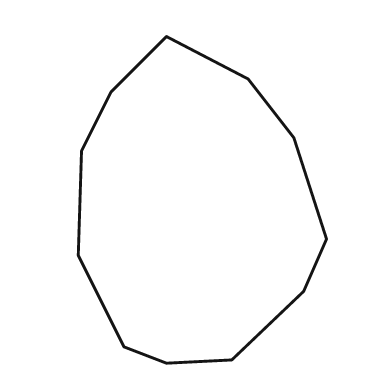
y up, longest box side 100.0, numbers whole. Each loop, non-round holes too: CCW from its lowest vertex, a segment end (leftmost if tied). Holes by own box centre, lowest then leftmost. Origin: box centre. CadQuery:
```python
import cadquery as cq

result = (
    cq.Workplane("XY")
    .moveTo(-11.0, -50.0)
    .lineTo(9.0, -49.0)
    .lineTo(31.0, -28.0)
    .lineTo(38.0, -12.0)
    .lineTo(28.0, 19.0)
    .lineTo(14.0, 37.0)
    .lineTo(-11.0, 50.0)
    .lineTo(-28.0, 33.0)
    .lineTo(-37.0, 15.0)
    .lineTo(-38.0, -17.0)
    .lineTo(-24.0, -45.0)
    .close()
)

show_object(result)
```